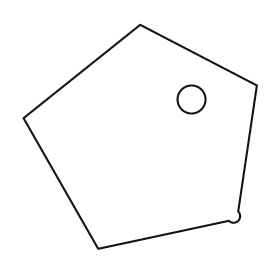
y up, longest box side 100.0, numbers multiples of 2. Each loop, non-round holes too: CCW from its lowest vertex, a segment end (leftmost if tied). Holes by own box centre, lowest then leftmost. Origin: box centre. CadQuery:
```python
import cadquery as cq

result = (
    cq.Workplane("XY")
    .moveTo(-18.0, -48.0)
    .lineTo(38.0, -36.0)
    .threePointArc((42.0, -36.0), (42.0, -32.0))
    .lineTo(50.0, 22.0)
    .lineTo(0.0, 48.0)
    .lineTo(-50.0, 8.0)
    .close()
    .moveTo(22.0, 16.0)
    .circle(6.0)
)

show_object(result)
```